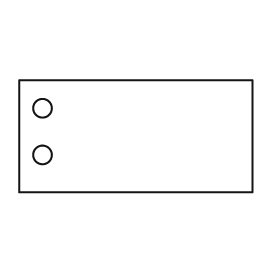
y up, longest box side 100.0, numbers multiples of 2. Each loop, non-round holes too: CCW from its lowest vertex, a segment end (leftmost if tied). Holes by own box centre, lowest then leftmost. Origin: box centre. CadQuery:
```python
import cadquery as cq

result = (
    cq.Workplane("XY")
    .moveTo(-50.0, -24.0)
    .lineTo(50.0, -24.0)
    .lineTo(50.0, 24.0)
    .lineTo(-50.0, 24.0)
    .close()
    .moveTo(-40.0, -8.0)
    .circle(4.0)
    .moveTo(-40.0, 12.0)
    .circle(4.0)
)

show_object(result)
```